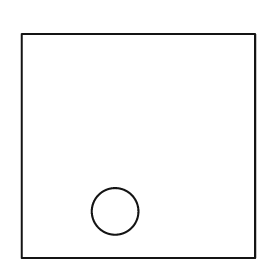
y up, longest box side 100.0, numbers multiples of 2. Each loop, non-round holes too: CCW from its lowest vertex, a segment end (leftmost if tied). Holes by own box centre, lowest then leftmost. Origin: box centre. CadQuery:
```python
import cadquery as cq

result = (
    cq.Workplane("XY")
    .moveTo(-50.0, -48.0)
    .lineTo(50.0, -48.0)
    .lineTo(50.0, 48.0)
    .lineTo(-50.0, 48.0)
    .close()
    .moveTo(-10.0, -28.0)
    .circle(10.0)
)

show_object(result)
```